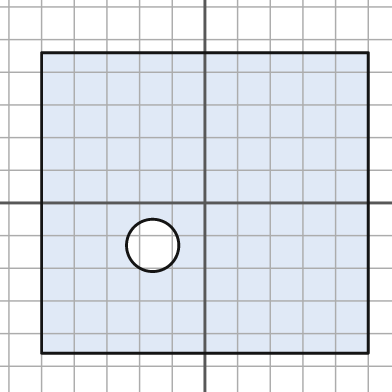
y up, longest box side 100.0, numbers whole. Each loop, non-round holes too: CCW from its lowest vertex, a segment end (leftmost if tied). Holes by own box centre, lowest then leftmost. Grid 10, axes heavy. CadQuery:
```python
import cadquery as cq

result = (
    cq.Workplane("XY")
    .moveTo(-50.0, -46.0)
    .lineTo(50.0, -46.0)
    .lineTo(50.0, 46.0)
    .lineTo(-50.0, 46.0)
    .close()
    .moveTo(-16.0, -13.0)
    .circle(8.0)
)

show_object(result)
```